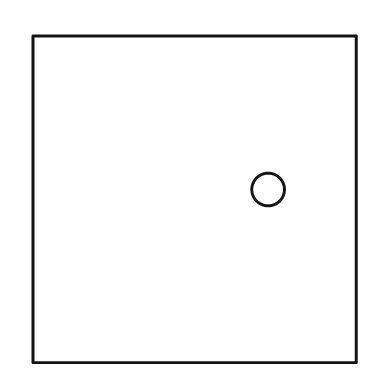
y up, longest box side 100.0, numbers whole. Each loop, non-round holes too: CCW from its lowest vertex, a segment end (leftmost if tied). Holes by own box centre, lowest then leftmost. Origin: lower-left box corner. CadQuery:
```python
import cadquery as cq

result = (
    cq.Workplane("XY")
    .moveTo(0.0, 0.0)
    .lineTo(99.0, 0.0)
    .lineTo(99.0, 100.0)
    .lineTo(0.0, 100.0)
    .close()
    .moveTo(72.0, 53.0)
    .circle(5.0)
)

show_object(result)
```